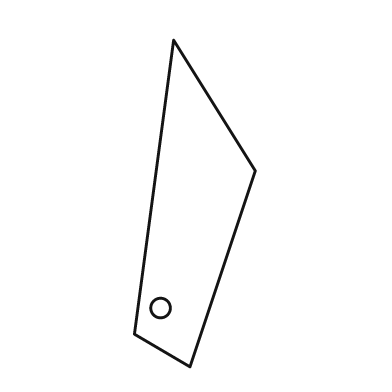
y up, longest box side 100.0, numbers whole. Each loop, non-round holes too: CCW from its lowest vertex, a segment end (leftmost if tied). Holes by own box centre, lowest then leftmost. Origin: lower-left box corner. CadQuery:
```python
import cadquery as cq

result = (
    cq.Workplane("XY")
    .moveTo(17.0, 0.0)
    .lineTo(37.0, 60.0)
    .lineTo(12.0, 100.0)
    .lineTo(0.0, 10.0)
    .close()
    .moveTo(8.0, 18.0)
    .circle(3.0)
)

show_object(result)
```